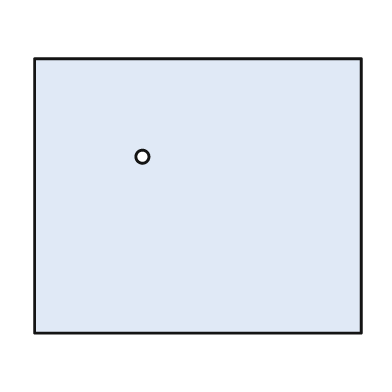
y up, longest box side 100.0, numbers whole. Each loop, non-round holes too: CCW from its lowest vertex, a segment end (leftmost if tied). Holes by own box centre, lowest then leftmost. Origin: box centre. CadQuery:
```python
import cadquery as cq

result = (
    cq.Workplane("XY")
    .moveTo(-50.0, -42.0)
    .lineTo(50.0, -42.0)
    .lineTo(50.0, 42.0)
    .lineTo(-50.0, 42.0)
    .close()
    .moveTo(-17.0, 12.0)
    .circle(2.0)
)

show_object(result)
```